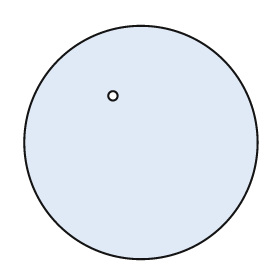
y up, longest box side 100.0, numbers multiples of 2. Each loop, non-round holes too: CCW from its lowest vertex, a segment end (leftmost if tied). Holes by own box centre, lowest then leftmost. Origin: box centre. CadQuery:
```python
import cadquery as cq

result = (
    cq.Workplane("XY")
    .moveTo(0.0, 0.0)
    .circle(50.0)
    .moveTo(-12.0, 20.0)
    .circle(2.0)
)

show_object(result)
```